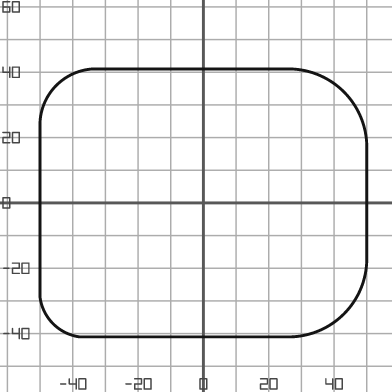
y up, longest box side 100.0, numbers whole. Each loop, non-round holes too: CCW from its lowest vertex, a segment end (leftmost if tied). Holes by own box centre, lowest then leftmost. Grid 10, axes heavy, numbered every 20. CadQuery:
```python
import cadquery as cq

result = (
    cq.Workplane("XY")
    .moveTo(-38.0, -41.0)
    .lineTo(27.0, -41.0)
    .threePointArc((43.0, -34.0), (50.0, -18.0))
    .lineTo(50.0, 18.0)
    .threePointArc((43.0, 34.0), (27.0, 41.0))
    .lineTo(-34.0, 41.0)
    .threePointArc((-45.0, 36.0), (-50.0, 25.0))
    .lineTo(-50.0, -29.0)
    .threePointArc((-46.0, -37.0), (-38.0, -41.0))
    .close()
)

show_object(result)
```